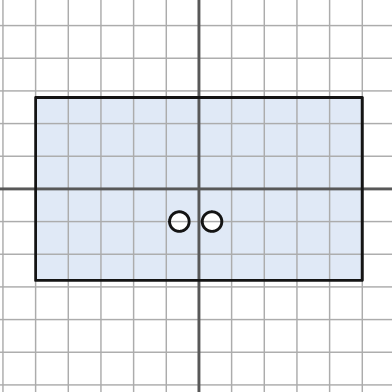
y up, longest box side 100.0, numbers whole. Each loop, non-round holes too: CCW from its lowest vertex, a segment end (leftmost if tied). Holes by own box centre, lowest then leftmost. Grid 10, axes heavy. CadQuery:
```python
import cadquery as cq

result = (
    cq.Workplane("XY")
    .moveTo(-50.0, -28.0)
    .lineTo(50.0, -28.0)
    .lineTo(50.0, 28.0)
    .lineTo(-50.0, 28.0)
    .close()
    .moveTo(-6.0, -10.0)
    .circle(3.0)
    .moveTo(4.0, -10.0)
    .circle(3.0)
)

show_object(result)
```